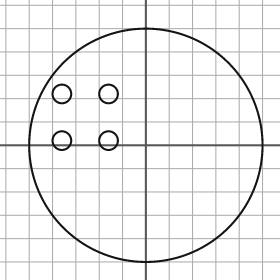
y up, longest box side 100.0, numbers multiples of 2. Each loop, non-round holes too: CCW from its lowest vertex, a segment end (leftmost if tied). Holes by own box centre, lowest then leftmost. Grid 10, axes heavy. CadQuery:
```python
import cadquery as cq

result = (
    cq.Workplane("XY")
    .moveTo(0.0, 0.0)
    .circle(50.0)
    .moveTo(-36.0, 2.0)
    .circle(4.0)
    .moveTo(-16.0, 2.0)
    .circle(4.0)
    .moveTo(-36.0, 22.0)
    .circle(4.0)
    .moveTo(-16.0, 22.0)
    .circle(4.0)
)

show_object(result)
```